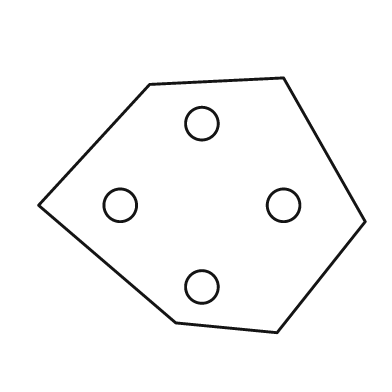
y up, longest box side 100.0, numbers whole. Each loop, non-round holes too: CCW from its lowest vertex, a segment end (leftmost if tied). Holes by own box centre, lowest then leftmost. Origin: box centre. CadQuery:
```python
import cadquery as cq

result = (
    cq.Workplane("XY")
    .moveTo(23.0, -39.0)
    .lineTo(50.0, -5.0)
    .lineTo(25.0, 39.0)
    .lineTo(-16.0, 37.0)
    .lineTo(-50.0, 0.0)
    .lineTo(-8.0, -36.0)
    .close()
    .moveTo(0.0, -25.0)
    .circle(5.0)
    .moveTo(-25.0, 0.0)
    .circle(5.0)
    .moveTo(25.0, 0.0)
    .circle(5.0)
    .moveTo(0.0, 25.0)
    .circle(5.0)
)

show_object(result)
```